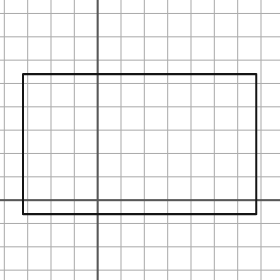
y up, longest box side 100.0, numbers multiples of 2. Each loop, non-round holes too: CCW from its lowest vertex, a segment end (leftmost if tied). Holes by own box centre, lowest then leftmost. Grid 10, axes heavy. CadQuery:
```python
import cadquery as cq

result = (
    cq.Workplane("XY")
    .moveTo(-32.0, -6.0)
    .lineTo(68.0, -6.0)
    .lineTo(68.0, 54.0)
    .lineTo(-32.0, 54.0)
    .close()
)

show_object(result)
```